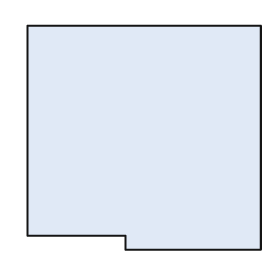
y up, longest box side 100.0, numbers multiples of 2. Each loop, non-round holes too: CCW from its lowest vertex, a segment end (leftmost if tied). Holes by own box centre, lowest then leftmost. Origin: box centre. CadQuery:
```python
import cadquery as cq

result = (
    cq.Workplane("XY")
    .moveTo(-8.0, -48.0)
    .lineTo(50.0, -48.0)
    .lineTo(50.0, 48.0)
    .lineTo(-50.0, 48.0)
    .lineTo(-50.0, -42.0)
    .lineTo(-8.0, -42.0)
    .close()
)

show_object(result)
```